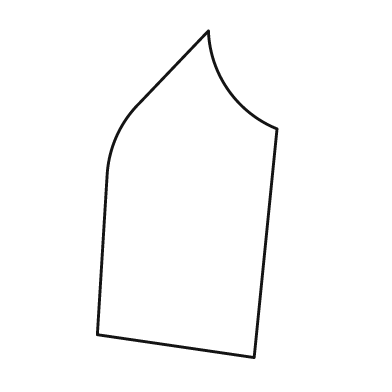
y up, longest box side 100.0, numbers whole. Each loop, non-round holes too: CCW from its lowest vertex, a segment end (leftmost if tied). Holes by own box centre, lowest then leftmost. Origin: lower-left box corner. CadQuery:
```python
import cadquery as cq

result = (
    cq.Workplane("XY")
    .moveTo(48.0, 0.0)
    .lineTo(55.0, 70.0)
    .threePointArc((40.0, 82.0), (34.0, 100.0))
    .lineTo(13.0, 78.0)
    .threePointArc((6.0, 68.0), (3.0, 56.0))
    .lineTo(0.0, 7.0)
    .close()
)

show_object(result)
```